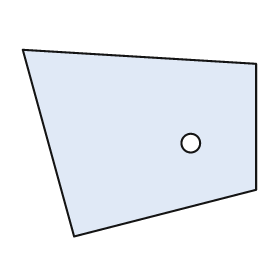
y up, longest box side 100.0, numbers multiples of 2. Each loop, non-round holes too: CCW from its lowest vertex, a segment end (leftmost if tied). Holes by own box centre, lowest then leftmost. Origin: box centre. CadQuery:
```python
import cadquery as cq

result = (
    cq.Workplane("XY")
    .moveTo(-28.0, -40.0)
    .lineTo(50.0, -20.0)
    .lineTo(50.0, 34.0)
    .lineTo(-50.0, 40.0)
    .close()
    .moveTo(22.0, 0.0)
    .circle(4.0)
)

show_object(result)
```